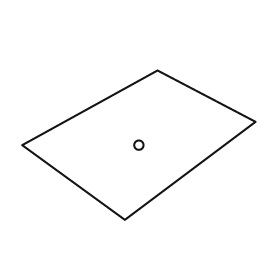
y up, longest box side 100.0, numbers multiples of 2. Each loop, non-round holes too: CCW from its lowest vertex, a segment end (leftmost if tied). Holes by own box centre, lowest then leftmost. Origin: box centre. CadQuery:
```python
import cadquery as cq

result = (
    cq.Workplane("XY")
    .moveTo(-6.0, -32.0)
    .lineTo(50.0, 10.0)
    .lineTo(8.0, 32.0)
    .lineTo(-50.0, 0.0)
    .close()
    .moveTo(0.0, 0.0)
    .circle(2.0)
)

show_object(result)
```